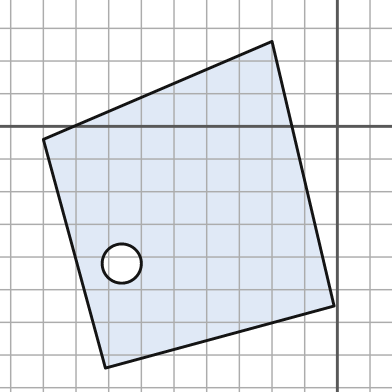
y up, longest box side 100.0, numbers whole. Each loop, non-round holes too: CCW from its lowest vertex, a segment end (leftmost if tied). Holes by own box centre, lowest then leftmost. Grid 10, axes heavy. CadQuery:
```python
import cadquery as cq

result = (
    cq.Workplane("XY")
    .moveTo(-71.0, -74.0)
    .lineTo(-1.0, -55.0)
    .lineTo(-20.0, 26.0)
    .lineTo(-90.0, -4.0)
    .close()
    .moveTo(-66.0, -42.0)
    .circle(6.0)
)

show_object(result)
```